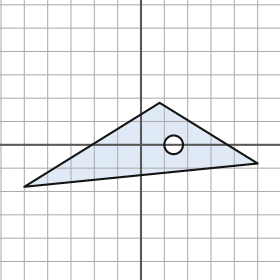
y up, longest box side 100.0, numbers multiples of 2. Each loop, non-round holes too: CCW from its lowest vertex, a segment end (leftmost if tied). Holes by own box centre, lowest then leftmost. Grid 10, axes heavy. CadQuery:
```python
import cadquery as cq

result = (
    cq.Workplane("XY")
    .moveTo(-50.0, -18.0)
    .lineTo(50.0, -8.0)
    .lineTo(8.0, 18.0)
    .close()
    .moveTo(14.0, 0.0)
    .circle(4.0)
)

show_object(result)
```